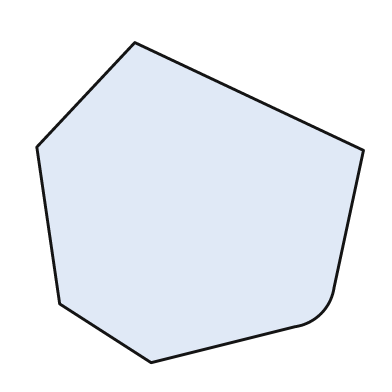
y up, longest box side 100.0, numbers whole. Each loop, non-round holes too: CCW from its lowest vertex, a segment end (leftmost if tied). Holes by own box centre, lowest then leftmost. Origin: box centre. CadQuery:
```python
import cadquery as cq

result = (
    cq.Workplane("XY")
    .moveTo(-15.0, -49.0)
    .lineTo(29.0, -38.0)
    .threePointArc((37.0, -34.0), (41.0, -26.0))
    .lineTo(50.0, 16.0)
    .lineTo(-20.0, 49.0)
    .lineTo(-50.0, 17.0)
    .lineTo(-43.0, -31.0)
    .close()
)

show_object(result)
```